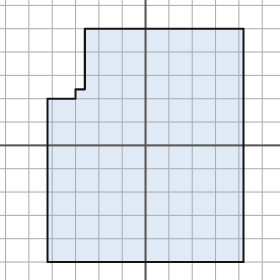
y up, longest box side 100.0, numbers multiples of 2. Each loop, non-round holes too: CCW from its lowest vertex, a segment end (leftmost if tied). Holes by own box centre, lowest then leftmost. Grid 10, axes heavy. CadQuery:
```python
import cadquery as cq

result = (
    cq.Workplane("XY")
    .moveTo(-42.0, -50.0)
    .lineTo(42.0, -50.0)
    .lineTo(42.0, 50.0)
    .lineTo(-26.0, 50.0)
    .lineTo(-26.0, 24.0)
    .lineTo(-30.0, 24.0)
    .lineTo(-30.0, 20.0)
    .lineTo(-42.0, 20.0)
    .close()
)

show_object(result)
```